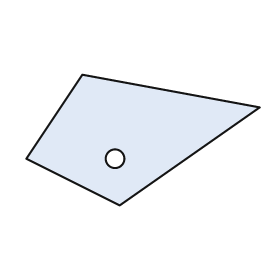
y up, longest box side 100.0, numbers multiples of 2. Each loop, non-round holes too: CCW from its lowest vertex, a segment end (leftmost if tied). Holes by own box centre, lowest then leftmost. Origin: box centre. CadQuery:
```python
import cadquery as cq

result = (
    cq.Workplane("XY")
    .moveTo(-10.0, -28.0)
    .lineTo(50.0, 14.0)
    .lineTo(-26.0, 28.0)
    .lineTo(-50.0, -8.0)
    .close()
    .moveTo(-12.0, -8.0)
    .circle(4.0)
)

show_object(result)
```